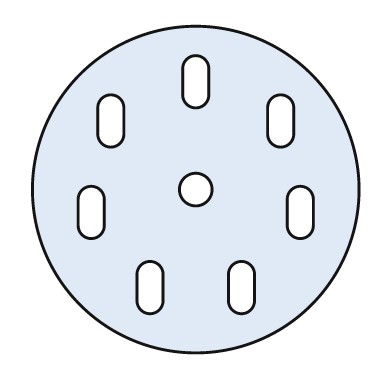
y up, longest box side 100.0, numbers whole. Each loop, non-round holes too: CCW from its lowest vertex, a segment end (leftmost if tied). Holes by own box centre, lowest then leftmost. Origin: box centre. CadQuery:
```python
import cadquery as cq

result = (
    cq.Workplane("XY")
    .moveTo(0.0, 0.0)
    .circle(50.0)
    .moveTo(-18.0, -34.0)
    .threePointArc((-14.0, -38.0), (-10.0, -34.0))
    .lineTo(-10.0, -26.0)
    .threePointArc((-14.0, -22.0), (-18.0, -26.0))
    .close()
    .moveTo(10.0, -34.0)
    .threePointArc((14.0, -38.0), (18.0, -34.0))
    .lineTo(18.0, -26.0)
    .threePointArc((14.0, -22.0), (10.0, -26.0))
    .close()
    .moveTo(-36.0, -11.0)
    .threePointArc((-32.0, -15.0), (-28.0, -11.0))
    .lineTo(-28.0, -3.0)
    .threePointArc((-32.0, 1.0), (-36.0, -3.0))
    .close()
    .moveTo(28.0, -11.0)
    .threePointArc((32.0, -15.0), (36.0, -11.0))
    .lineTo(36.0, -3.0)
    .threePointArc((32.0, 1.0), (28.0, -3.0))
    .close()
    .moveTo(0.0, 0.0)
    .circle(5.0)
    .moveTo(-30.0, 17.0)
    .threePointArc((-26.0, 13.0), (-22.0, 17.0))
    .lineTo(-22.0, 25.0)
    .threePointArc((-26.0, 29.0), (-30.0, 25.0))
    .close()
    .moveTo(22.0, 17.0)
    .threePointArc((26.0, 13.0), (30.0, 17.0))
    .lineTo(30.0, 25.0)
    .threePointArc((26.0, 29.0), (22.0, 25.0))
    .close()
    .moveTo(-4.0, 29.0)
    .threePointArc((0.0, 25.0), (4.0, 29.0))
    .lineTo(4.0, 37.0)
    .threePointArc((0.0, 41.0), (-4.0, 37.0))
    .close()
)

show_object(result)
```